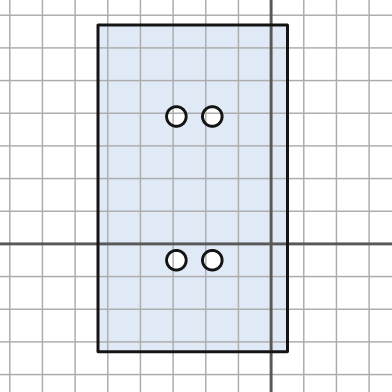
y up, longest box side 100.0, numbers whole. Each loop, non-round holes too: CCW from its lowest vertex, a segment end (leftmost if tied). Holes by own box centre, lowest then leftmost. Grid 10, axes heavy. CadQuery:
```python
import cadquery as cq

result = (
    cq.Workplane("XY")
    .moveTo(-53.0, -33.0)
    .lineTo(5.0, -33.0)
    .lineTo(5.0, 67.0)
    .lineTo(-53.0, 67.0)
    .close()
    .moveTo(-29.0, -5.0)
    .circle(3.0)
    .moveTo(-18.0, -5.0)
    .circle(3.0)
    .moveTo(-29.0, 39.0)
    .circle(3.0)
    .moveTo(-18.0, 39.0)
    .circle(3.0)
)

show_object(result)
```